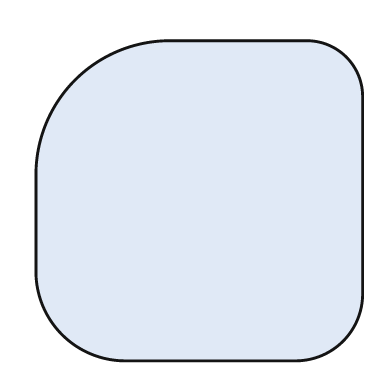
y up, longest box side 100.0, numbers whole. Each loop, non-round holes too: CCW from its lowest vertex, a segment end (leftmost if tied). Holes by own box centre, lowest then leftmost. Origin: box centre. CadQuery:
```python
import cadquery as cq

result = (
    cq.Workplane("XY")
    .moveTo(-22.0, -49.0)
    .lineTo(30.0, -49.0)
    .threePointArc((44.0, -43.0), (50.0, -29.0))
    .lineTo(50.0, 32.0)
    .threePointArc((45.0, 44.0), (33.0, 49.0))
    .lineTo(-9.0, 49.0)
    .threePointArc((-38.0, 37.0), (-50.0, 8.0))
    .lineTo(-50.0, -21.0)
    .threePointArc((-42.0, -41.0), (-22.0, -49.0))
    .close()
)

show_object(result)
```